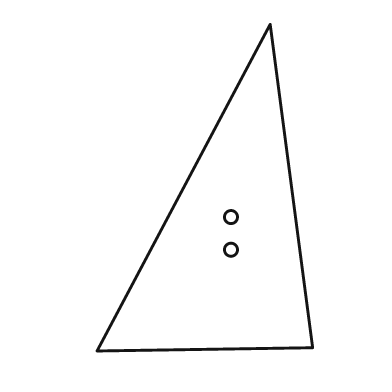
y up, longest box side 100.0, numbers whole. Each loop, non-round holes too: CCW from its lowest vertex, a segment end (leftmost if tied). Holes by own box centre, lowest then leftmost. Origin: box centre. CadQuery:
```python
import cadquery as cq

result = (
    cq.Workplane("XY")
    .moveTo(-33.0, -50.0)
    .lineTo(33.0, -49.0)
    .lineTo(20.0, 50.0)
    .close()
    .moveTo(8.0, -19.0)
    .circle(2.0)
    .moveTo(8.0, -9.0)
    .circle(2.0)
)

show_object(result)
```